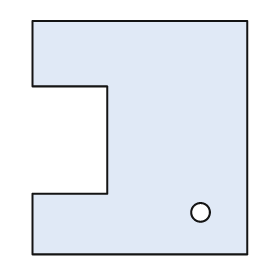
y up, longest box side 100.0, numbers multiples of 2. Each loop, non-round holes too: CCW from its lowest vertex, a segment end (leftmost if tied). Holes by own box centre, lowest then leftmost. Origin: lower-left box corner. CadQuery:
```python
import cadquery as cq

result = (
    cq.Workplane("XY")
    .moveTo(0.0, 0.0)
    .lineTo(92.0, 0.0)
    .lineTo(92.0, 100.0)
    .lineTo(0.0, 100.0)
    .lineTo(0.0, 72.0)
    .lineTo(32.0, 72.0)
    .lineTo(32.0, 26.0)
    .lineTo(0.0, 26.0)
    .close()
    .moveTo(72.0, 18.0)
    .circle(4.0)
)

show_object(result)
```